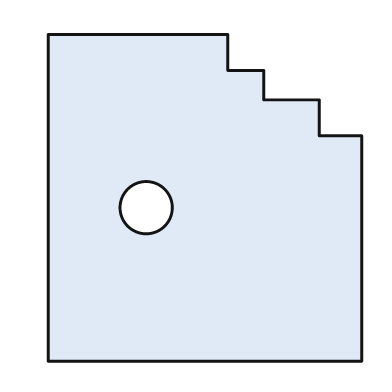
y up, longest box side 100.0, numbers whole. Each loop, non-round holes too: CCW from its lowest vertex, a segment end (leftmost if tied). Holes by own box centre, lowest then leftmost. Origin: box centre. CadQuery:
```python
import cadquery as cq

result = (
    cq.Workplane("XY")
    .moveTo(-48.0, -50.0)
    .lineTo(48.0, -50.0)
    .lineTo(48.0, 19.0)
    .lineTo(35.0, 19.0)
    .lineTo(35.0, 30.0)
    .lineTo(18.0, 30.0)
    .lineTo(18.0, 39.0)
    .lineTo(7.0, 39.0)
    .lineTo(7.0, 50.0)
    .lineTo(-48.0, 50.0)
    .close()
    .moveTo(-18.0, -3.0)
    .circle(8.0)
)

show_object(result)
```